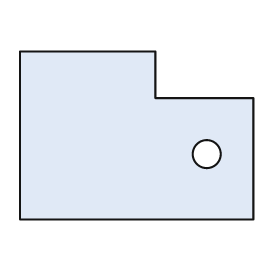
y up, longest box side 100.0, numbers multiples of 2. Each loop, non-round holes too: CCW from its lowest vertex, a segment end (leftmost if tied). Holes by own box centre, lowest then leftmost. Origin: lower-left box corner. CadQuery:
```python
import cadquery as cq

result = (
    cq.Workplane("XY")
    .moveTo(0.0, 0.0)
    .lineTo(100.0, 0.0)
    .lineTo(100.0, 52.0)
    .lineTo(58.0, 52.0)
    .lineTo(58.0, 72.0)
    .lineTo(0.0, 72.0)
    .close()
    .moveTo(80.0, 28.0)
    .circle(6.0)
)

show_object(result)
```